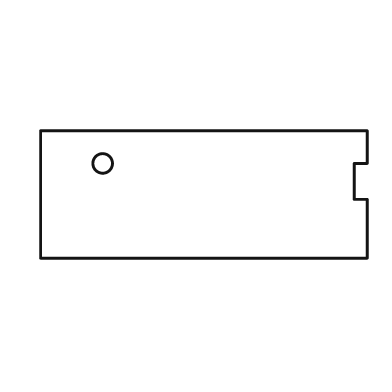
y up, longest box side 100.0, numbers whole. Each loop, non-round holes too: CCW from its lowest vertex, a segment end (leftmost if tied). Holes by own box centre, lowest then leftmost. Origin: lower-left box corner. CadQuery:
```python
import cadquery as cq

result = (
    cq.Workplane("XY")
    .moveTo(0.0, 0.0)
    .lineTo(100.0, 0.0)
    .lineTo(100.0, 18.0)
    .lineTo(96.0, 18.0)
    .lineTo(96.0, 29.0)
    .lineTo(100.0, 29.0)
    .lineTo(100.0, 39.0)
    .lineTo(0.0, 39.0)
    .close()
    .moveTo(19.0, 29.0)
    .circle(3.0)
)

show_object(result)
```